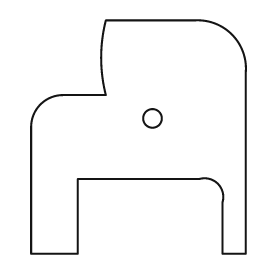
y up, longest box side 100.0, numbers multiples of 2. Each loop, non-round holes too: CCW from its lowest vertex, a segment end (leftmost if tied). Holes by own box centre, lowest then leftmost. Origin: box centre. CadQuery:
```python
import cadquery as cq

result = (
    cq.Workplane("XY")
    .moveTo(-46.0, -50.0)
    .lineTo(-26.0, -50.0)
    .lineTo(-26.0, -18.0)
    .lineTo(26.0, -18.0)
    .threePointArc((34.0, -20.0), (36.0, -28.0))
    .lineTo(36.0, -50.0)
    .lineTo(46.0, -50.0)
    .lineTo(46.0, 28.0)
    .threePointArc((40.0, 44.0), (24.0, 50.0))
    .lineTo(-14.0, 50.0)
    .threePointArc((-16.0, 34.0), (-14.0, 18.0))
    .lineTo(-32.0, 18.0)
    .threePointArc((-42.0, 14.0), (-46.0, 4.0))
    .close()
    .moveTo(6.0, 8.0)
    .circle(4.0)
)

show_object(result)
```